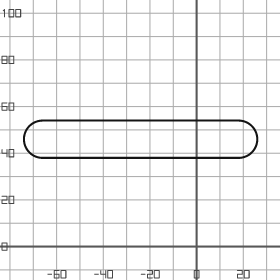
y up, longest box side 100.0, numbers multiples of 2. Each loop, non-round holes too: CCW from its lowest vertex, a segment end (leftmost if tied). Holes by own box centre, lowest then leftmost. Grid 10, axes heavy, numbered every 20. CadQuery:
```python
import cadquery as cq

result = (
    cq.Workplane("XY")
    .moveTo(-66.0, 38.0)
    .lineTo(18.0, 38.0)
    .threePointArc((26.0, 46.0), (18.0, 54.0))
    .lineTo(-66.0, 54.0)
    .threePointArc((-74.0, 46.0), (-66.0, 38.0))
    .close()
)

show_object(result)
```